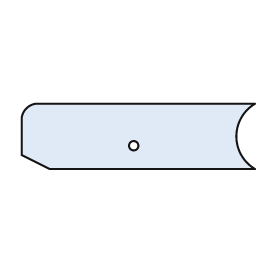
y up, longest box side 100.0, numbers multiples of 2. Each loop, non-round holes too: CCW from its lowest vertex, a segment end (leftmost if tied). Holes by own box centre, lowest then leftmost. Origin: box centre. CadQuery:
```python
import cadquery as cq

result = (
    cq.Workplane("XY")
    .moveTo(-38.0, -14.0)
    .lineTo(50.0, -14.0)
    .threePointArc((42.0, 0.0), (50.0, 14.0))
    .lineTo(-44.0, 14.0)
    .threePointArc((-48.0, 12.0), (-50.0, 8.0))
    .lineTo(-50.0, -8.0)
    .close()
    .moveTo(-2.0, -4.0)
    .circle(2.0)
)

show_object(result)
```